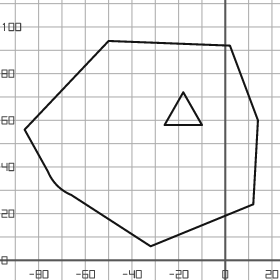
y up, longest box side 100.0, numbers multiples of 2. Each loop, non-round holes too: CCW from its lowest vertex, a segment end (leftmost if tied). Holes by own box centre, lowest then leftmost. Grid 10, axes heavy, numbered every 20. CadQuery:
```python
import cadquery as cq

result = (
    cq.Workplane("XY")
    .moveTo(-32.0, 6.0)
    .lineTo(12.0, 24.0)
    .lineTo(14.0, 60.0)
    .lineTo(2.0, 92.0)
    .lineTo(-50.0, 94.0)
    .lineTo(-86.0, 56.0)
    .lineTo(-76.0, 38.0)
    .threePointArc((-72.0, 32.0), (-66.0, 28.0))
    .close()
    .moveTo(-26.0, 58.0)
    .lineTo(-10.0, 58.0)
    .lineTo(-18.0, 72.0)
    .close()
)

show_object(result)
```